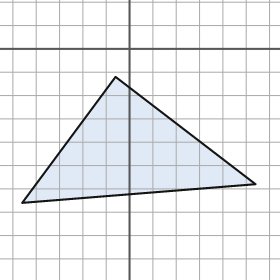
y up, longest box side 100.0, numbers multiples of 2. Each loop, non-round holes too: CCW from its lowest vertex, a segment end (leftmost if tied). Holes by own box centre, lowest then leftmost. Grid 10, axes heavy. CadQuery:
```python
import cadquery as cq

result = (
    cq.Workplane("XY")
    .moveTo(-46.0, -66.0)
    .lineTo(54.0, -58.0)
    .lineTo(-6.0, -12.0)
    .close()
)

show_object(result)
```